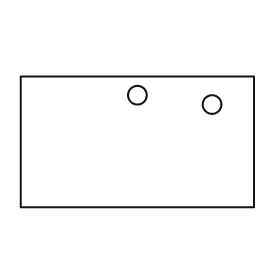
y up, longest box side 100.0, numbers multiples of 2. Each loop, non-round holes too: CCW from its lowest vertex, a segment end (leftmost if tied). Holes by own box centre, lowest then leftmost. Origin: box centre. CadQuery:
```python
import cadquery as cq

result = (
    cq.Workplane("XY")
    .moveTo(-50.0, -28.0)
    .lineTo(50.0, -28.0)
    .lineTo(50.0, 28.0)
    .lineTo(-50.0, 28.0)
    .close()
    .moveTo(32.0, 16.0)
    .circle(4.0)
    .moveTo(0.0, 20.0)
    .circle(4.0)
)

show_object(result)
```